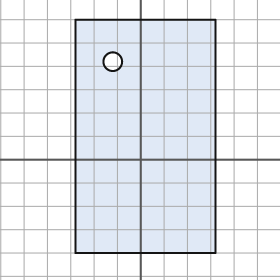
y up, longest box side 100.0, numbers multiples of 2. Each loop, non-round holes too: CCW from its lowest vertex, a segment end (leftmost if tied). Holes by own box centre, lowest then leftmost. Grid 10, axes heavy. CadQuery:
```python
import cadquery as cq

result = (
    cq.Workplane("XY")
    .moveTo(-28.0, -40.0)
    .lineTo(32.0, -40.0)
    .lineTo(32.0, 60.0)
    .lineTo(-28.0, 60.0)
    .close()
    .moveTo(-12.0, 42.0)
    .circle(4.0)
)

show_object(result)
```